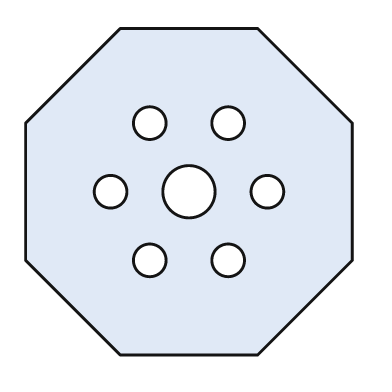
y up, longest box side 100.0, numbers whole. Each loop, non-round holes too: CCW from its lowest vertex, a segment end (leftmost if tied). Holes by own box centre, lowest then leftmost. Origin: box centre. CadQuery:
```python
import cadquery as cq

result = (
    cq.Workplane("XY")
    .moveTo(-21.0, -50.0)
    .lineTo(21.0, -50.0)
    .lineTo(50.0, -21.0)
    .lineTo(50.0, 21.0)
    .lineTo(21.0, 50.0)
    .lineTo(-21.0, 50.0)
    .lineTo(-50.0, 21.0)
    .lineTo(-50.0, -21.0)
    .close()
    .moveTo(-12.0, -21.0)
    .circle(5.0)
    .moveTo(12.0, -21.0)
    .circle(5.0)
    .moveTo(-24.0, 0.0)
    .circle(5.0)
    .moveTo(0.0, 0.0)
    .circle(8.0)
    .moveTo(24.0, 0.0)
    .circle(5.0)
    .moveTo(-12.0, 21.0)
    .circle(5.0)
    .moveTo(12.0, 21.0)
    .circle(5.0)
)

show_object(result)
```